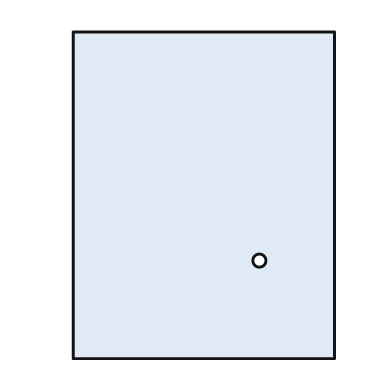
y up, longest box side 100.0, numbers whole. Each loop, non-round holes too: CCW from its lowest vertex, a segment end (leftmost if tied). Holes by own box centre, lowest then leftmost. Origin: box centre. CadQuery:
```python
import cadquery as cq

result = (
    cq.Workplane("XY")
    .moveTo(-40.0, -50.0)
    .lineTo(40.0, -50.0)
    .lineTo(40.0, 50.0)
    .lineTo(-40.0, 50.0)
    .close()
    .moveTo(17.0, -20.0)
    .circle(2.0)
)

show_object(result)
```